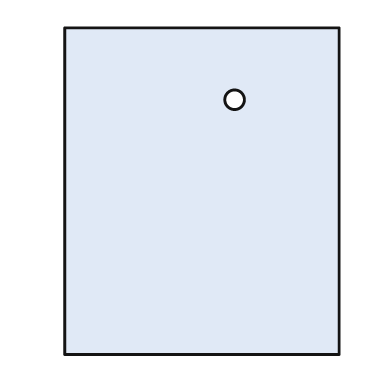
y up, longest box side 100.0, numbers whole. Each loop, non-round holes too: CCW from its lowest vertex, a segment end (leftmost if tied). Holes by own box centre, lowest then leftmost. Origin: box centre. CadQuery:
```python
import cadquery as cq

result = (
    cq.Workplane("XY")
    .moveTo(-42.0, -50.0)
    .lineTo(42.0, -50.0)
    .lineTo(42.0, 50.0)
    .lineTo(-42.0, 50.0)
    .close()
    .moveTo(10.0, 28.0)
    .circle(3.0)
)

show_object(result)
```